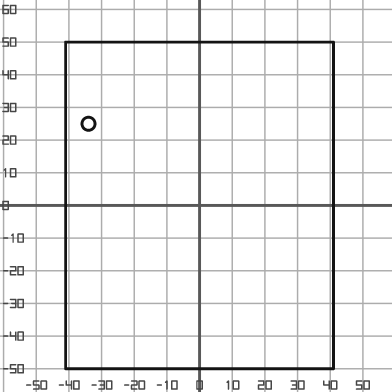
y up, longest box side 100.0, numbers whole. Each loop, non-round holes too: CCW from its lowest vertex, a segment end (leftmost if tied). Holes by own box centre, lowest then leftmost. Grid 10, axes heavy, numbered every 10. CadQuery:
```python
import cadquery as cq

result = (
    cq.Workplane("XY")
    .moveTo(-41.0, -50.0)
    .lineTo(41.0, -50.0)
    .lineTo(41.0, 50.0)
    .lineTo(-41.0, 50.0)
    .close()
    .moveTo(-34.0, 25.0)
    .circle(2.0)
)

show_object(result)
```